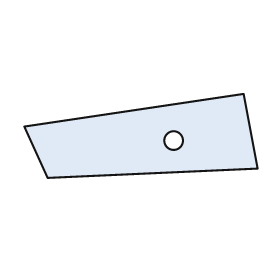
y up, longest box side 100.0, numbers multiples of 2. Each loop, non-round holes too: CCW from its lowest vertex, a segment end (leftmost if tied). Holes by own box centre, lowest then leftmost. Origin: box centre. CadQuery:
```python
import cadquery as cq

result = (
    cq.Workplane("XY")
    .moveTo(-40.0, -18.0)
    .lineTo(50.0, -14.0)
    .lineTo(44.0, 18.0)
    .lineTo(-50.0, 4.0)
    .close()
    .moveTo(14.0, -2.0)
    .circle(4.0)
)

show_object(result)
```